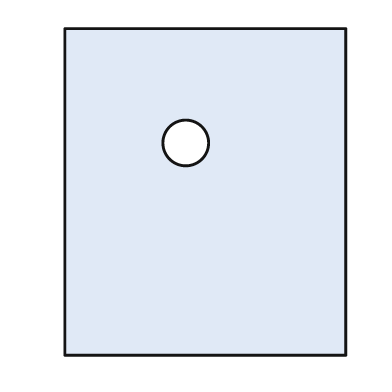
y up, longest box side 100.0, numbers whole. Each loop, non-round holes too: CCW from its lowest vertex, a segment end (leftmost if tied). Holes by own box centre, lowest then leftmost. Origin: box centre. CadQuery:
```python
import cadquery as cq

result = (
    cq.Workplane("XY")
    .moveTo(-43.0, -50.0)
    .lineTo(43.0, -50.0)
    .lineTo(43.0, 50.0)
    .lineTo(-43.0, 50.0)
    .close()
    .moveTo(-6.0, 15.0)
    .circle(7.0)
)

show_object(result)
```